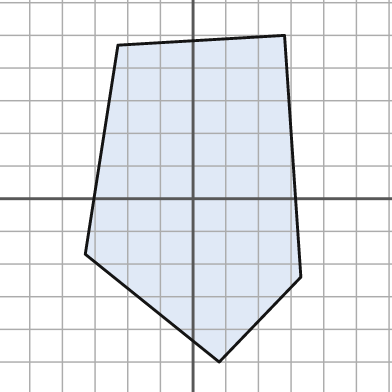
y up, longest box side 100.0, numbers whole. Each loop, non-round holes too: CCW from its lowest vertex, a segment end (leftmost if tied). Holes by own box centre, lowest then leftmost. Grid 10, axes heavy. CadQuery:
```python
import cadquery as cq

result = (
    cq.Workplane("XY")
    .moveTo(8.0, -50.0)
    .lineTo(33.0, -24.0)
    .lineTo(28.0, 50.0)
    .lineTo(-23.0, 47.0)
    .lineTo(-33.0, -17.0)
    .close()
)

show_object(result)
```